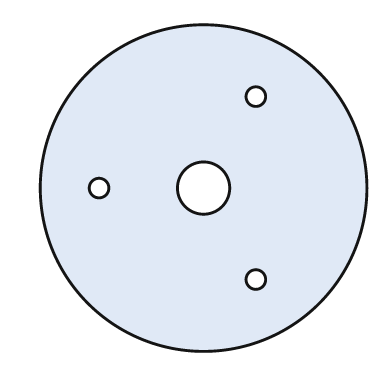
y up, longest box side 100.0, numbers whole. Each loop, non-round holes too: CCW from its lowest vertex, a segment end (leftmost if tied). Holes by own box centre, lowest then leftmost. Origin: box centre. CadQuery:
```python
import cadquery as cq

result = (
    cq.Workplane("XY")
    .moveTo(0.0, 0.0)
    .circle(50.0)
    .moveTo(16.0, -28.0)
    .circle(3.0)
    .moveTo(-32.0, 0.0)
    .circle(3.0)
    .moveTo(0.0, 0.0)
    .circle(8.0)
    .moveTo(16.0, 28.0)
    .circle(3.0)
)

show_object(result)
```